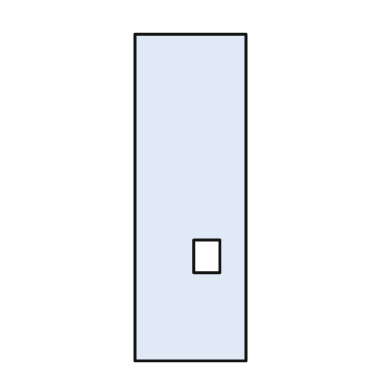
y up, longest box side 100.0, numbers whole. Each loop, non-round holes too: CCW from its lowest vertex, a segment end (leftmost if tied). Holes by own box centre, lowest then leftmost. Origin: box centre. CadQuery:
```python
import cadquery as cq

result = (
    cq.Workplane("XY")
    .moveTo(-17.0, -50.0)
    .lineTo(17.0, -50.0)
    .lineTo(17.0, 50.0)
    .lineTo(-17.0, 50.0)
    .close()
    .moveTo(1.0, -23.0)
    .lineTo(9.0, -23.0)
    .lineTo(9.0, -13.0)
    .lineTo(1.0, -13.0)
    .close()
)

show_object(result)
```